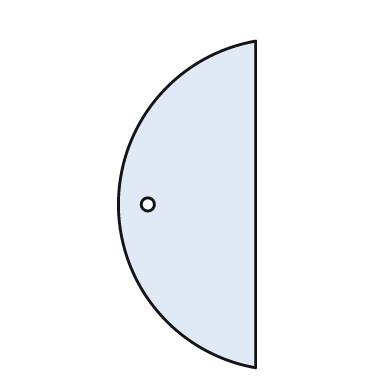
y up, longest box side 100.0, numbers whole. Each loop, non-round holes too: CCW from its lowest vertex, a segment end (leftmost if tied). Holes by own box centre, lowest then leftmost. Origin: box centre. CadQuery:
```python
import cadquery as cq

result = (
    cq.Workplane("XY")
    .moveTo(21.0, -50.0)
    .lineTo(21.0, 50.0)
    .threePointArc((-21.0, 0.0), (21.0, -50.0))
    .close()
    .moveTo(-12.0, 0.0)
    .circle(2.0)
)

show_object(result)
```